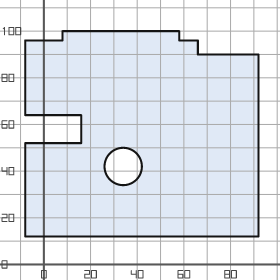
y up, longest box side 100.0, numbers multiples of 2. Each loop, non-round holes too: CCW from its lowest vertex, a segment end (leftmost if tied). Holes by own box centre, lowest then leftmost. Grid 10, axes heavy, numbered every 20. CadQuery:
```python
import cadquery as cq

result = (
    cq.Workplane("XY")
    .moveTo(-8.0, 12.0)
    .lineTo(92.0, 12.0)
    .lineTo(92.0, 90.0)
    .lineTo(66.0, 90.0)
    .lineTo(66.0, 96.0)
    .lineTo(58.0, 96.0)
    .lineTo(58.0, 100.0)
    .lineTo(8.0, 100.0)
    .lineTo(8.0, 96.0)
    .lineTo(-8.0, 96.0)
    .lineTo(-8.0, 64.0)
    .lineTo(16.0, 64.0)
    .lineTo(16.0, 52.0)
    .lineTo(-8.0, 52.0)
    .close()
    .moveTo(34.0, 42.0)
    .circle(8.0)
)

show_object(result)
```